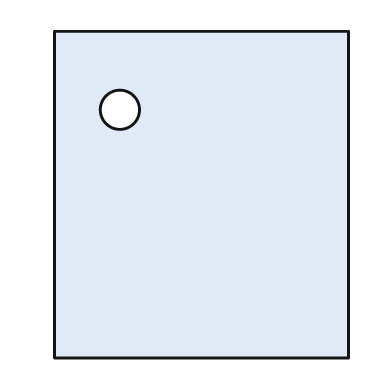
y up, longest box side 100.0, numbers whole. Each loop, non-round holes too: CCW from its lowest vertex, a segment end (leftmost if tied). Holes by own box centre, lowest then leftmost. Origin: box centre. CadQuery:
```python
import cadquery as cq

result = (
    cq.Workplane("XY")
    .moveTo(-45.0, -50.0)
    .lineTo(45.0, -50.0)
    .lineTo(45.0, 50.0)
    .lineTo(-45.0, 50.0)
    .close()
    .moveTo(-25.0, 26.0)
    .circle(6.0)
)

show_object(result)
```